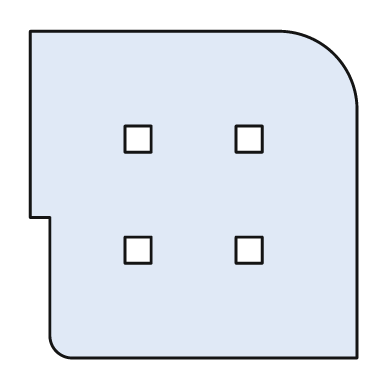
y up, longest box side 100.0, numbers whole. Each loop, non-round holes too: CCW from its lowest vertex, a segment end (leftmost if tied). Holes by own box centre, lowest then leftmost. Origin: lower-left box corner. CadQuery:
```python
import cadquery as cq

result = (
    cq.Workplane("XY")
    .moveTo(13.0, 0.0)
    .lineTo(100.0, 0.0)
    .lineTo(100.0, 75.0)
    .threePointArc((93.0, 93.0), (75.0, 100.0))
    .lineTo(0.0, 100.0)
    .lineTo(0.0, 43.0)
    .lineTo(6.0, 43.0)
    .lineTo(6.0, 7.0)
    .threePointArc((8.0, 2.0), (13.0, 0.0))
    .close()
    .moveTo(29.0, 29.0)
    .lineTo(37.0, 29.0)
    .lineTo(37.0, 37.0)
    .lineTo(29.0, 37.0)
    .close()
    .moveTo(63.0, 29.0)
    .lineTo(71.0, 29.0)
    .lineTo(71.0, 37.0)
    .lineTo(63.0, 37.0)
    .close()
    .moveTo(29.0, 63.0)
    .lineTo(37.0, 63.0)
    .lineTo(37.0, 71.0)
    .lineTo(29.0, 71.0)
    .close()
    .moveTo(63.0, 63.0)
    .lineTo(71.0, 63.0)
    .lineTo(71.0, 71.0)
    .lineTo(63.0, 71.0)
    .close()
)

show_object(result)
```